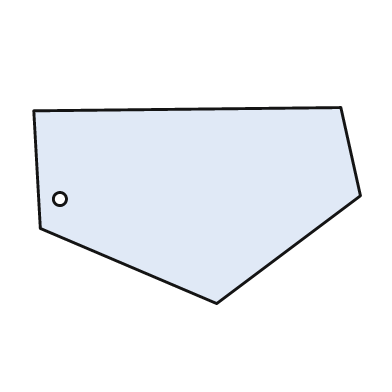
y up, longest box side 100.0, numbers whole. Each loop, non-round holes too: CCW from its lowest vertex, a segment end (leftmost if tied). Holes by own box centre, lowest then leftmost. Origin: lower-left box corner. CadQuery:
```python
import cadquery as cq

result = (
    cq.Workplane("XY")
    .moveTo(56.0, 0.0)
    .lineTo(100.0, 33.0)
    .lineTo(94.0, 60.0)
    .lineTo(0.0, 59.0)
    .lineTo(2.0, 23.0)
    .close()
    .moveTo(8.0, 32.0)
    .circle(2.0)
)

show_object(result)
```